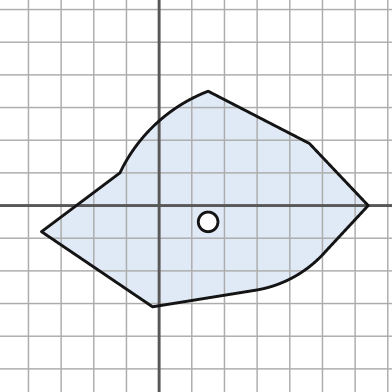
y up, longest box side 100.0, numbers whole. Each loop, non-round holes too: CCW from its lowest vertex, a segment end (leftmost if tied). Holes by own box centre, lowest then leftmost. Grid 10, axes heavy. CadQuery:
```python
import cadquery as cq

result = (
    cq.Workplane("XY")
    .moveTo(-2.0, -31.0)
    .lineTo(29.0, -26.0)
    .threePointArc((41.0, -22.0), (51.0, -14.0))
    .lineTo(64.0, 0.0)
    .lineTo(46.0, 19.0)
    .lineTo(15.0, 35.0)
    .threePointArc((-1.0, 25.0), (-12.0, 10.0))
    .lineTo(-36.0, -8.0)
    .close()
    .moveTo(15.0, -5.0)
    .circle(3.0)
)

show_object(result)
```